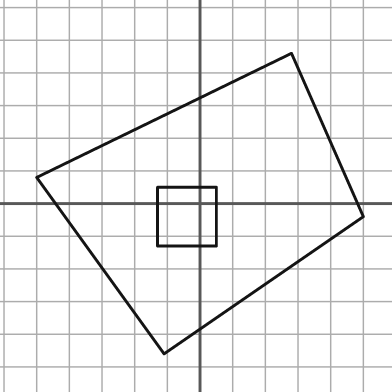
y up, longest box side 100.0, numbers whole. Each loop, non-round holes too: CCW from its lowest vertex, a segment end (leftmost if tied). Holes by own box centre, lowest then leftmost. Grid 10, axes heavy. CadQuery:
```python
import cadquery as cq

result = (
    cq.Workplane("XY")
    .moveTo(-11.0, -46.0)
    .lineTo(50.0, -4.0)
    .lineTo(28.0, 46.0)
    .lineTo(-50.0, 8.0)
    .close()
    .moveTo(-13.0, -13.0)
    .lineTo(5.0, -13.0)
    .lineTo(5.0, 5.0)
    .lineTo(-13.0, 5.0)
    .close()
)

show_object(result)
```